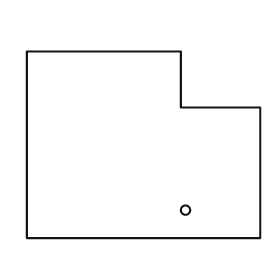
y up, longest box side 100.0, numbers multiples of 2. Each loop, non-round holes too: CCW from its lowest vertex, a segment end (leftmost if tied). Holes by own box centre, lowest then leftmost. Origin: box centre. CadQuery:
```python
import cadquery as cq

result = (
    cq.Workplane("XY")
    .moveTo(-50.0, -40.0)
    .lineTo(50.0, -40.0)
    .lineTo(50.0, 16.0)
    .lineTo(16.0, 16.0)
    .lineTo(16.0, 40.0)
    .lineTo(-50.0, 40.0)
    .close()
    .moveTo(18.0, -28.0)
    .circle(2.0)
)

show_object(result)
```